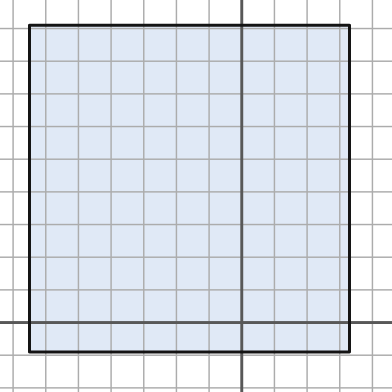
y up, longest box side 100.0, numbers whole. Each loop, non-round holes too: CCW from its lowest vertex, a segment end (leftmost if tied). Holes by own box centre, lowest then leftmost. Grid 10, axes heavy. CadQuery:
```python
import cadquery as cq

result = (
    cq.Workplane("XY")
    .moveTo(-65.0, -9.0)
    .lineTo(33.0, -9.0)
    .lineTo(33.0, 91.0)
    .lineTo(-65.0, 91.0)
    .close()
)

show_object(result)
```